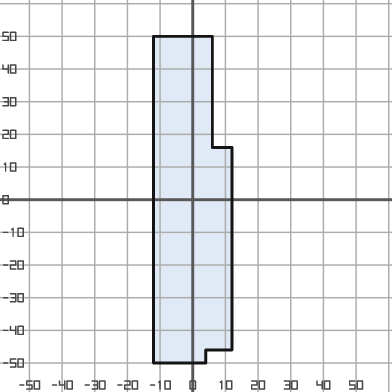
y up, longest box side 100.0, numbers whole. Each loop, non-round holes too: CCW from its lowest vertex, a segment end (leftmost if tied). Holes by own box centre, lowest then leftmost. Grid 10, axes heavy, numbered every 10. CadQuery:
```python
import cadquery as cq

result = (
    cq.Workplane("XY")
    .moveTo(-12.0, -50.0)
    .lineTo(4.0, -50.0)
    .lineTo(4.0, -46.0)
    .lineTo(12.0, -46.0)
    .lineTo(12.0, 16.0)
    .lineTo(6.0, 16.0)
    .lineTo(6.0, 50.0)
    .lineTo(-12.0, 50.0)
    .close()
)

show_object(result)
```